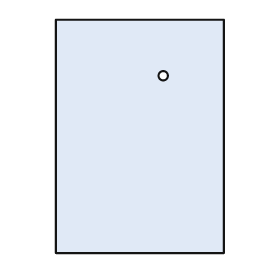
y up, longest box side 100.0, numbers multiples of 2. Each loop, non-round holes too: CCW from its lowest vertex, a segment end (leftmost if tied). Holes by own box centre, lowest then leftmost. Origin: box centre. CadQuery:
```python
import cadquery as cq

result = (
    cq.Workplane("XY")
    .moveTo(-36.0, -50.0)
    .lineTo(36.0, -50.0)
    .lineTo(36.0, 50.0)
    .lineTo(-36.0, 50.0)
    .close()
    .moveTo(10.0, 26.0)
    .circle(2.0)
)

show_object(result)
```